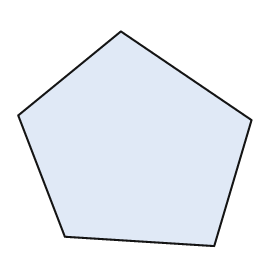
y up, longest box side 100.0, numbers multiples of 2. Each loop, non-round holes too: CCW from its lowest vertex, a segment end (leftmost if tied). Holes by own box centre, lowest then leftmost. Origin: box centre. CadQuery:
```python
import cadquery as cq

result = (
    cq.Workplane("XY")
    .moveTo(34.0, -46.0)
    .lineTo(50.0, 8.0)
    .lineTo(-6.0, 46.0)
    .lineTo(-50.0, 10.0)
    .lineTo(-30.0, -42.0)
    .close()
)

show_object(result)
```